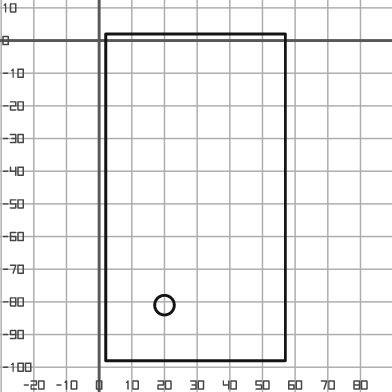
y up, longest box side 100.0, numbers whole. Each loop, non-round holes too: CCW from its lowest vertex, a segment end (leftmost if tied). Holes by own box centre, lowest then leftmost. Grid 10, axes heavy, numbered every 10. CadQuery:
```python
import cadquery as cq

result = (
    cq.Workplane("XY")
    .moveTo(2.0, -98.0)
    .lineTo(57.0, -98.0)
    .lineTo(57.0, 2.0)
    .lineTo(2.0, 2.0)
    .close()
    .moveTo(20.0, -81.0)
    .circle(3.0)
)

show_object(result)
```